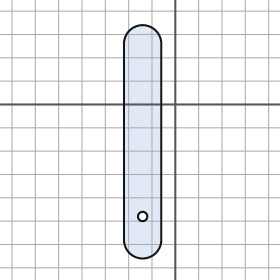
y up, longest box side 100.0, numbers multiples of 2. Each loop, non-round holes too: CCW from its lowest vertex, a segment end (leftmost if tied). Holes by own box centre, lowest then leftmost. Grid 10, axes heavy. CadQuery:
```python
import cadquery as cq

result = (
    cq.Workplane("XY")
    .moveTo(-22.0, -58.0)
    .threePointArc((-14.0, -66.0), (-6.0, -58.0))
    .lineTo(-6.0, 26.0)
    .threePointArc((-14.0, 34.0), (-22.0, 26.0))
    .close()
    .moveTo(-14.0, -48.0)
    .circle(2.0)
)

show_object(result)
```